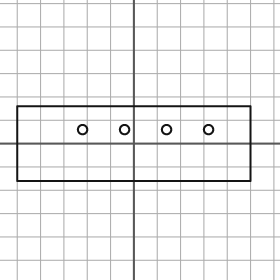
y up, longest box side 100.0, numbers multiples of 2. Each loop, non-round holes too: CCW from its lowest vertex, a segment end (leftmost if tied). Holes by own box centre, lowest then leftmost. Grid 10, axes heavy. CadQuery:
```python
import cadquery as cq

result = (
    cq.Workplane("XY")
    .moveTo(-50.0, -16.0)
    .lineTo(50.0, -16.0)
    .lineTo(50.0, 16.0)
    .lineTo(-50.0, 16.0)
    .close()
    .moveTo(-22.0, 6.0)
    .circle(2.0)
    .moveTo(-4.0, 6.0)
    .circle(2.0)
    .moveTo(14.0, 6.0)
    .circle(2.0)
    .moveTo(32.0, 6.0)
    .circle(2.0)
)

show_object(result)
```